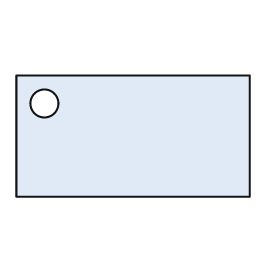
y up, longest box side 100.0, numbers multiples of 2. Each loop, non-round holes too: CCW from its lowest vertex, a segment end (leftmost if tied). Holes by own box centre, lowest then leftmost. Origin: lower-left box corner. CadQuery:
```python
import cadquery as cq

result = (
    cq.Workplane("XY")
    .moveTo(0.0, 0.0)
    .lineTo(100.0, 0.0)
    .lineTo(100.0, 52.0)
    .lineTo(0.0, 52.0)
    .close()
    .moveTo(12.0, 40.0)
    .circle(6.0)
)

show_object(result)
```